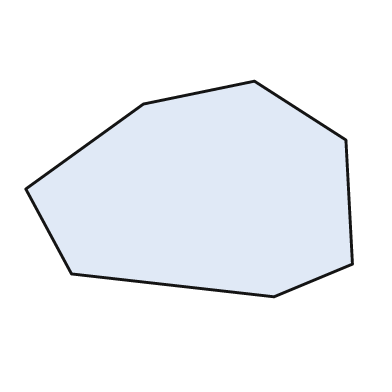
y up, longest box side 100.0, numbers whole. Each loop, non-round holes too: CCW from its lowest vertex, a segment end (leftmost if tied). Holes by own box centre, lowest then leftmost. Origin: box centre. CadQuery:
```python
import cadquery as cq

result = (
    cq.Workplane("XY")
    .moveTo(26.0, -33.0)
    .lineTo(50.0, -23.0)
    .lineTo(48.0, 15.0)
    .lineTo(20.0, 33.0)
    .lineTo(-14.0, 26.0)
    .lineTo(-50.0, 0.0)
    .lineTo(-36.0, -26.0)
    .close()
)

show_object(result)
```